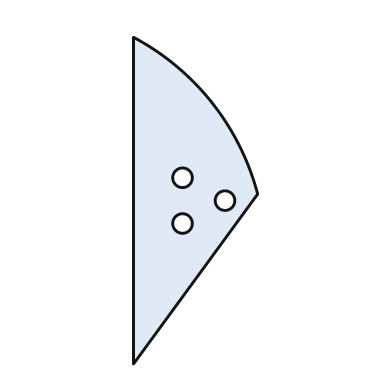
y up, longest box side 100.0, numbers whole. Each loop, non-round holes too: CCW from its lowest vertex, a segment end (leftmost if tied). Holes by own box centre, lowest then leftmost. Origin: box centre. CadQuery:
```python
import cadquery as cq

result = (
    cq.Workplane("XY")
    .moveTo(-19.0, -50.0)
    .lineTo(19.0, 2.0)
    .threePointArc((5.0, 30.0), (-19.0, 50.0))
    .close()
    .moveTo(-4.0, -7.0)
    .circle(3.0)
    .moveTo(9.0, 0.0)
    .circle(3.0)
    .moveTo(-4.0, 7.0)
    .circle(3.0)
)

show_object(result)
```